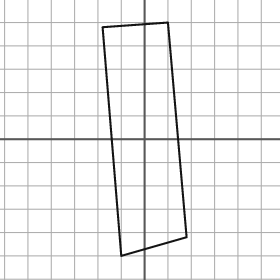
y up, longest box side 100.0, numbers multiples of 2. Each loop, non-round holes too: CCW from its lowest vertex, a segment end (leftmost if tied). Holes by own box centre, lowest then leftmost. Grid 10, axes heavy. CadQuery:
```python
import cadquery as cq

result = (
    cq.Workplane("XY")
    .moveTo(-10.0, -50.0)
    .lineTo(18.0, -42.0)
    .lineTo(10.0, 50.0)
    .lineTo(-18.0, 48.0)
    .close()
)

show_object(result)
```